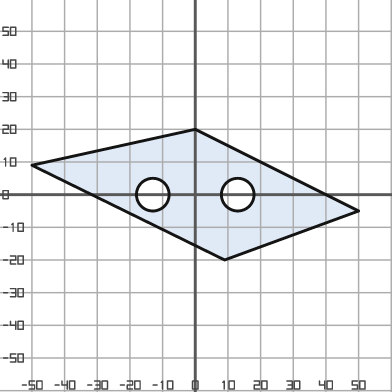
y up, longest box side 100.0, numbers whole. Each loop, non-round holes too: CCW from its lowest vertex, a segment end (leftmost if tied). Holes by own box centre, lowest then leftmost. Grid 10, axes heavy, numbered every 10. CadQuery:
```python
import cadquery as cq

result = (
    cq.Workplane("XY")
    .moveTo(9.0, -20.0)
    .lineTo(50.0, -5.0)
    .lineTo(0.0, 20.0)
    .lineTo(-50.0, 9.0)
    .close()
    .moveTo(-13.0, 0.0)
    .circle(5.0)
    .moveTo(13.0, 0.0)
    .circle(5.0)
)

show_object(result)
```